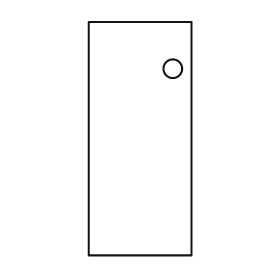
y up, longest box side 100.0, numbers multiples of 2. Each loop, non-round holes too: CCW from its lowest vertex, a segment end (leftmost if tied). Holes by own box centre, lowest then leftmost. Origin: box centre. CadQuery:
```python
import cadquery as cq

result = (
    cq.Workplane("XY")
    .moveTo(-22.0, -50.0)
    .lineTo(22.0, -50.0)
    .lineTo(22.0, 50.0)
    .lineTo(-22.0, 50.0)
    .close()
    .moveTo(14.0, 30.0)
    .circle(4.0)
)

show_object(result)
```